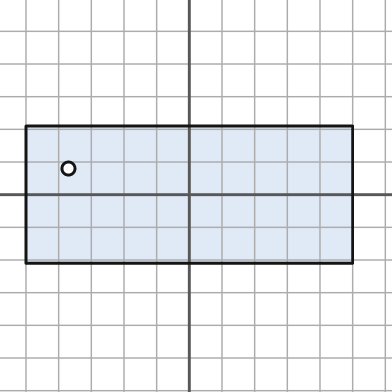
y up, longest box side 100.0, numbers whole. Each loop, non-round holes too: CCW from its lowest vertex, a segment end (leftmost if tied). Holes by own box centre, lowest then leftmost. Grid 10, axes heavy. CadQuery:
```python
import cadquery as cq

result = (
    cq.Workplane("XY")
    .moveTo(-50.0, -21.0)
    .lineTo(50.0, -21.0)
    .lineTo(50.0, 21.0)
    .lineTo(-50.0, 21.0)
    .close()
    .moveTo(-37.0, 8.0)
    .circle(2.0)
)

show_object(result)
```